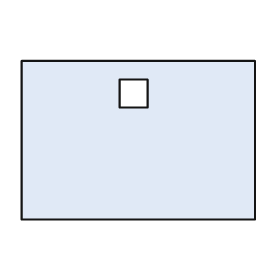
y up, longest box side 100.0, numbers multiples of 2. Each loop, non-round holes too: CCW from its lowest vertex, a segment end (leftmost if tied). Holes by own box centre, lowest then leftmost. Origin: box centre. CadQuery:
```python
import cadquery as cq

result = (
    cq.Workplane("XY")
    .moveTo(-50.0, -34.0)
    .lineTo(50.0, -34.0)
    .lineTo(50.0, 34.0)
    .lineTo(-50.0, 34.0)
    .close()
    .moveTo(-8.0, 14.0)
    .lineTo(4.0, 14.0)
    .lineTo(4.0, 26.0)
    .lineTo(-8.0, 26.0)
    .close()
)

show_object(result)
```